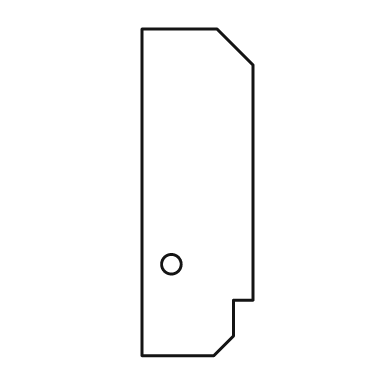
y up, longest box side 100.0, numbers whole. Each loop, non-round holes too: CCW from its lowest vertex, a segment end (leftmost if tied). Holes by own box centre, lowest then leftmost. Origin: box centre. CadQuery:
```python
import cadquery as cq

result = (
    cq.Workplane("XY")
    .moveTo(-17.0, -50.0)
    .lineTo(5.0, -50.0)
    .lineTo(11.0, -44.0)
    .lineTo(11.0, -33.0)
    .lineTo(17.0, -33.0)
    .lineTo(17.0, 39.0)
    .lineTo(6.0, 50.0)
    .lineTo(-17.0, 50.0)
    .close()
    .moveTo(-8.0, -22.0)
    .circle(3.0)
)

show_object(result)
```